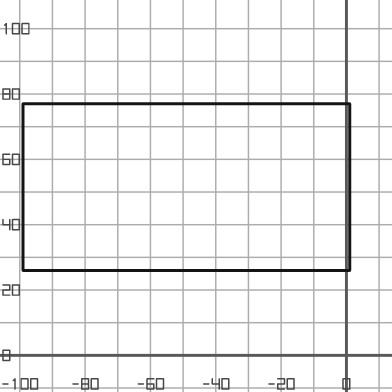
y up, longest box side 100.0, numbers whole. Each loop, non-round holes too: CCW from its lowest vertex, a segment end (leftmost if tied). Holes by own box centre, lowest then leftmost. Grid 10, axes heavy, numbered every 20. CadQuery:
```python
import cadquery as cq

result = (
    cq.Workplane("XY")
    .moveTo(-99.0, 26.0)
    .lineTo(1.0, 26.0)
    .lineTo(1.0, 77.0)
    .lineTo(-99.0, 77.0)
    .close()
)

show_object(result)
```